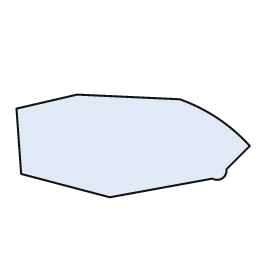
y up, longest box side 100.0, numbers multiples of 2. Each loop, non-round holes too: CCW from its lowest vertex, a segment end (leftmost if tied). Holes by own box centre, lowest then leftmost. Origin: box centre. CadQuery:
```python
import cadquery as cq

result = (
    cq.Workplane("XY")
    .moveTo(-10.0, -22.0)
    .lineTo(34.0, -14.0)
    .threePointArc((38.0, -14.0), (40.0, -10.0))
    .lineTo(50.0, 0.0)
    .threePointArc((36.0, 12.0), (20.0, 20.0))
    .lineTo(-24.0, 22.0)
    .lineTo(-50.0, 16.0)
    .lineTo(-48.0, -12.0)
    .close()
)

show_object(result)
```